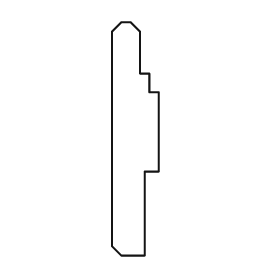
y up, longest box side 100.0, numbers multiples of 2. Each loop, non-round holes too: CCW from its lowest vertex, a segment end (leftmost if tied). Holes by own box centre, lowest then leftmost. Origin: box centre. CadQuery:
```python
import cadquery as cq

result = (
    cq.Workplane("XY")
    .moveTo(-6.0, -50.0)
    .lineTo(4.0, -50.0)
    .lineTo(4.0, -14.0)
    .lineTo(10.0, -14.0)
    .lineTo(10.0, 20.0)
    .lineTo(6.0, 20.0)
    .lineTo(6.0, 28.0)
    .lineTo(2.0, 28.0)
    .lineTo(2.0, 46.0)
    .lineTo(-2.0, 50.0)
    .lineTo(-6.0, 50.0)
    .lineTo(-10.0, 46.0)
    .lineTo(-10.0, -46.0)
    .close()
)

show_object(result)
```